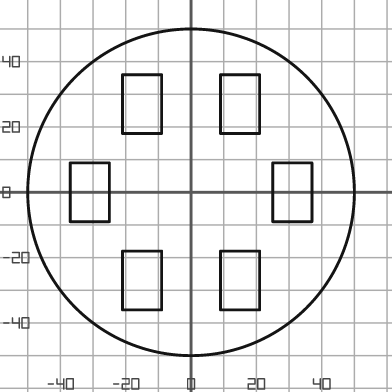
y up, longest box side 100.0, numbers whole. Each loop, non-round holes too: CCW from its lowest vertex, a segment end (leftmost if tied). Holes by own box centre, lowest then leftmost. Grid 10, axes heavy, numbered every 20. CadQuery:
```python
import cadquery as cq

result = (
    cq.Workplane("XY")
    .moveTo(0.0, 0.0)
    .circle(50.0)
    .moveTo(-21.0, -36.0)
    .lineTo(-9.0, -36.0)
    .lineTo(-9.0, -18.0)
    .lineTo(-21.0, -18.0)
    .close()
    .moveTo(9.0, -36.0)
    .lineTo(21.0, -36.0)
    .lineTo(21.0, -18.0)
    .lineTo(9.0, -18.0)
    .close()
    .moveTo(-37.0, -9.0)
    .lineTo(-25.0, -9.0)
    .lineTo(-25.0, 9.0)
    .lineTo(-37.0, 9.0)
    .close()
    .moveTo(25.0, -9.0)
    .lineTo(37.0, -9.0)
    .lineTo(37.0, 9.0)
    .lineTo(25.0, 9.0)
    .close()
    .moveTo(-21.0, 18.0)
    .lineTo(-9.0, 18.0)
    .lineTo(-9.0, 36.0)
    .lineTo(-21.0, 36.0)
    .close()
    .moveTo(9.0, 18.0)
    .lineTo(21.0, 18.0)
    .lineTo(21.0, 36.0)
    .lineTo(9.0, 36.0)
    .close()
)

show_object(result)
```